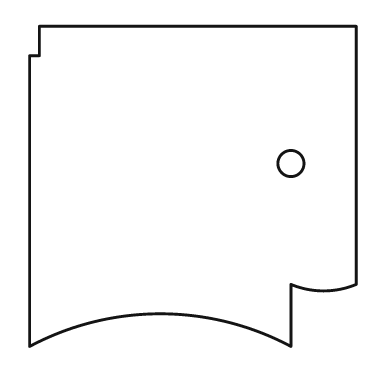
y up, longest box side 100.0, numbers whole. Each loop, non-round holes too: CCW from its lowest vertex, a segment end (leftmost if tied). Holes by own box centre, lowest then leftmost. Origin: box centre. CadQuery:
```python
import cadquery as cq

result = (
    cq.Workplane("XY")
    .moveTo(-50.0, -49.0)
    .threePointArc((-10.0, -39.0), (30.0, -49.0))
    .lineTo(30.0, -30.0)
    .threePointArc((40.0, -32.0), (50.0, -30.0))
    .lineTo(50.0, 49.0)
    .lineTo(-47.0, 49.0)
    .lineTo(-47.0, 40.0)
    .lineTo(-50.0, 40.0)
    .close()
    .moveTo(30.0, 7.0)
    .circle(4.0)
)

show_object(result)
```